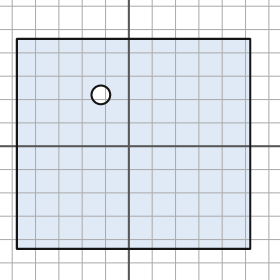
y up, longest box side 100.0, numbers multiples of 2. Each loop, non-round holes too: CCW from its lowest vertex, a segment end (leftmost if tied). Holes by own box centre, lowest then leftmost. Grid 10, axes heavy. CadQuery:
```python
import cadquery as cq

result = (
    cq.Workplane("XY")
    .moveTo(-48.0, -44.0)
    .lineTo(52.0, -44.0)
    .lineTo(52.0, 46.0)
    .lineTo(-48.0, 46.0)
    .close()
    .moveTo(-12.0, 22.0)
    .circle(4.0)
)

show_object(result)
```